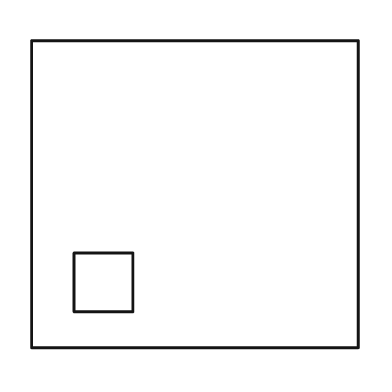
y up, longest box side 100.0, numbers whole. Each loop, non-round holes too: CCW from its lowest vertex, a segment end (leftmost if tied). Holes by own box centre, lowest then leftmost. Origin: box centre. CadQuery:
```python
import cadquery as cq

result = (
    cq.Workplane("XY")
    .moveTo(-50.0, -47.0)
    .lineTo(50.0, -47.0)
    .lineTo(50.0, 47.0)
    .lineTo(-50.0, 47.0)
    .close()
    .moveTo(-37.0, -36.0)
    .lineTo(-19.0, -36.0)
    .lineTo(-19.0, -18.0)
    .lineTo(-37.0, -18.0)
    .close()
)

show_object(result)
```